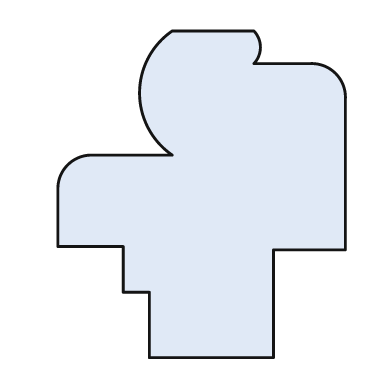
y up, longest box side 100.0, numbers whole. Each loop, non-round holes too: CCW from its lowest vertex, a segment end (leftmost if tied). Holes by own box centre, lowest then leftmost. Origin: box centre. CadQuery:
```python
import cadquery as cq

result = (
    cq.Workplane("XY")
    .moveTo(-16.0, -50.0)
    .lineTo(22.0, -50.0)
    .lineTo(22.0, -17.0)
    .lineTo(44.0, -17.0)
    .lineTo(44.0, 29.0)
    .threePointArc((41.0, 37.0), (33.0, 40.0))
    .lineTo(16.0, 40.0)
    .threePointArc((18.0, 45.0), (16.0, 50.0))
    .lineTo(-9.0, 50.0)
    .threePointArc((-19.0, 31.0), (-9.0, 12.0))
    .lineTo(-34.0, 12.0)
    .threePointArc((-41.0, 9.0), (-44.0, 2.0))
    .lineTo(-44.0, -16.0)
    .lineTo(-24.0, -16.0)
    .lineTo(-24.0, -30.0)
    .lineTo(-16.0, -30.0)
    .close()
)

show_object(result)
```